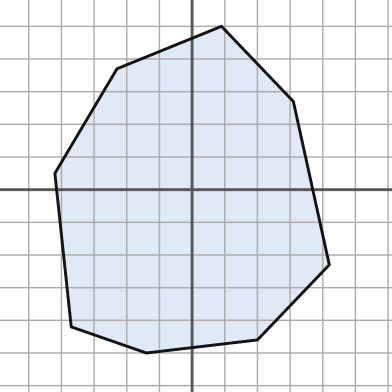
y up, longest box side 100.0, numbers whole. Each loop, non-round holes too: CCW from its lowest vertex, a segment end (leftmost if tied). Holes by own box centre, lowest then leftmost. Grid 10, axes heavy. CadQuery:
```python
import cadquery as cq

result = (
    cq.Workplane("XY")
    .moveTo(-14.0, -50.0)
    .lineTo(20.0, -46.0)
    .lineTo(42.0, -23.0)
    .lineTo(31.0, 27.0)
    .lineTo(9.0, 50.0)
    .lineTo(-23.0, 37.0)
    .lineTo(-42.0, 5.0)
    .lineTo(-37.0, -42.0)
    .close()
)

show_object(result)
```